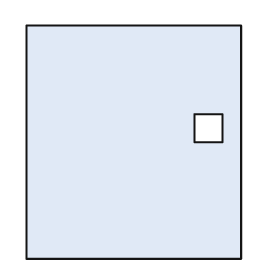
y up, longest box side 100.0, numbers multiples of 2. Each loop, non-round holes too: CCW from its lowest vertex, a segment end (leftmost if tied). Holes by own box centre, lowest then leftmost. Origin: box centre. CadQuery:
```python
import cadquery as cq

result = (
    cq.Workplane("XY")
    .moveTo(-46.0, -50.0)
    .lineTo(46.0, -50.0)
    .lineTo(46.0, 50.0)
    .lineTo(-46.0, 50.0)
    .close()
    .moveTo(26.0, 0.0)
    .lineTo(38.0, 0.0)
    .lineTo(38.0, 12.0)
    .lineTo(26.0, 12.0)
    .close()
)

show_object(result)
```